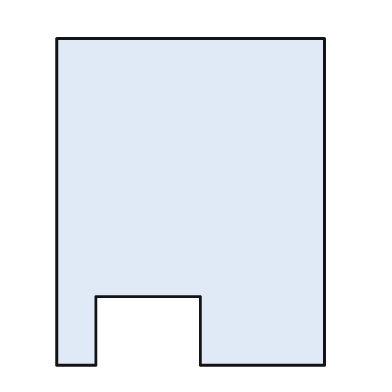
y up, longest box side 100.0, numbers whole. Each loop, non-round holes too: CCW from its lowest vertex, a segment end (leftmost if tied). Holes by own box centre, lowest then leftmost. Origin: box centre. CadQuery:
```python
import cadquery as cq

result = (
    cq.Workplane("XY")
    .moveTo(-41.0, -50.0)
    .lineTo(-29.0, -50.0)
    .lineTo(-29.0, -29.0)
    .lineTo(3.0, -29.0)
    .lineTo(3.0, -50.0)
    .lineTo(41.0, -50.0)
    .lineTo(41.0, 50.0)
    .lineTo(-41.0, 50.0)
    .close()
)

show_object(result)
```